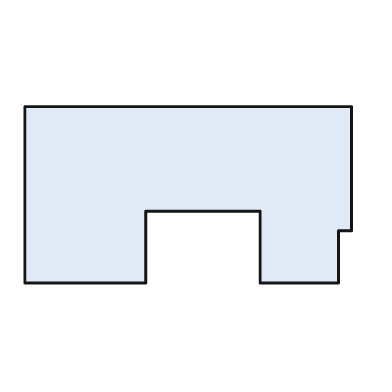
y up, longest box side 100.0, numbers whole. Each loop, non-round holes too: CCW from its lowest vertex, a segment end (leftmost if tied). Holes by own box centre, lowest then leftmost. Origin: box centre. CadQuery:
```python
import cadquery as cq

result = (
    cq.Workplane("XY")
    .moveTo(-50.0, -27.0)
    .lineTo(-13.0, -27.0)
    .lineTo(-13.0, -5.0)
    .lineTo(22.0, -5.0)
    .lineTo(22.0, -27.0)
    .lineTo(46.0, -27.0)
    .lineTo(46.0, -11.0)
    .lineTo(50.0, -11.0)
    .lineTo(50.0, 27.0)
    .lineTo(-50.0, 27.0)
    .close()
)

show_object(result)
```